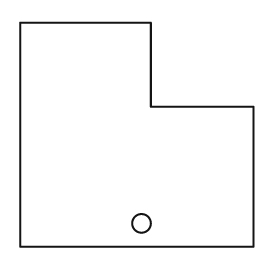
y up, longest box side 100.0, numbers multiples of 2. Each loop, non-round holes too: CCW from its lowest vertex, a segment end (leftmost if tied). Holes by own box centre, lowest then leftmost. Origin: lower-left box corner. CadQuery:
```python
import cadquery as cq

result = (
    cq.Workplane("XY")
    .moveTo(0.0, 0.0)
    .lineTo(100.0, 0.0)
    .lineTo(100.0, 60.0)
    .lineTo(56.0, 60.0)
    .lineTo(56.0, 96.0)
    .lineTo(0.0, 96.0)
    .close()
    .moveTo(52.0, 10.0)
    .circle(4.0)
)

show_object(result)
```